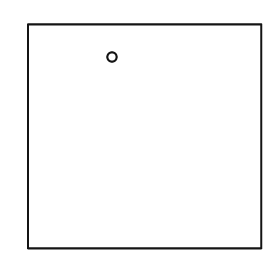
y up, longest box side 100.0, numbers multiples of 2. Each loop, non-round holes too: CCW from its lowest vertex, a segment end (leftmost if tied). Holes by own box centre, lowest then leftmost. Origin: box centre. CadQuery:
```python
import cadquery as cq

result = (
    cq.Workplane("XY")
    .moveTo(-50.0, -48.0)
    .lineTo(50.0, -48.0)
    .lineTo(50.0, 48.0)
    .lineTo(-50.0, 48.0)
    .close()
    .moveTo(-14.0, 34.0)
    .circle(2.0)
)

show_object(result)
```